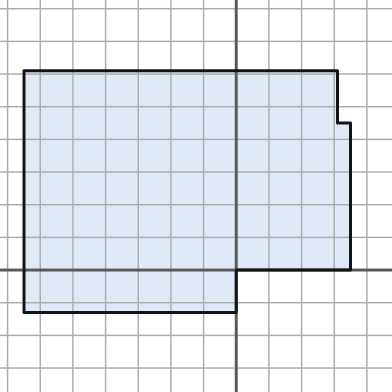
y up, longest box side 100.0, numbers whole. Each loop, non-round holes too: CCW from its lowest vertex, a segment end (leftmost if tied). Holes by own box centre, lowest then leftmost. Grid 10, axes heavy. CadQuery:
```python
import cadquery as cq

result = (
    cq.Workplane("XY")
    .moveTo(-65.0, -13.0)
    .lineTo(0.0, -13.0)
    .lineTo(0.0, 0.0)
    .lineTo(35.0, 0.0)
    .lineTo(35.0, 45.0)
    .lineTo(31.0, 45.0)
    .lineTo(31.0, 61.0)
    .lineTo(-65.0, 61.0)
    .close()
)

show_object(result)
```